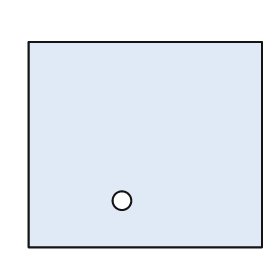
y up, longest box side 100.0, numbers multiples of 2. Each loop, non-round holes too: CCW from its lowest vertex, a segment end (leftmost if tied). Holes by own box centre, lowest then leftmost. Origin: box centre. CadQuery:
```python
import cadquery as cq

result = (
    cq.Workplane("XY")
    .moveTo(-50.0, -44.0)
    .lineTo(50.0, -44.0)
    .lineTo(50.0, 44.0)
    .lineTo(-50.0, 44.0)
    .close()
    .moveTo(-10.0, -24.0)
    .circle(4.0)
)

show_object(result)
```